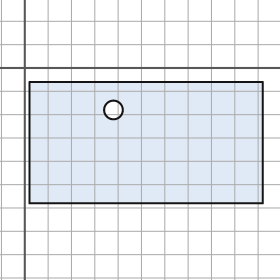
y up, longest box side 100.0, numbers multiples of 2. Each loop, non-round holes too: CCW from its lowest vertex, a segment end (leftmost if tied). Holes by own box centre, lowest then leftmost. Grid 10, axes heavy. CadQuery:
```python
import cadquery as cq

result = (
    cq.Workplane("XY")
    .moveTo(2.0, -58.0)
    .lineTo(102.0, -58.0)
    .lineTo(102.0, -6.0)
    .lineTo(2.0, -6.0)
    .close()
    .moveTo(38.0, -18.0)
    .circle(4.0)
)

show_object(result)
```